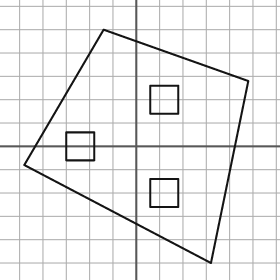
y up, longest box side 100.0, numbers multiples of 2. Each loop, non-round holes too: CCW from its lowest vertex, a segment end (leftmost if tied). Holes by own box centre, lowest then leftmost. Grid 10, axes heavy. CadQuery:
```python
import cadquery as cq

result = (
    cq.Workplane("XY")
    .moveTo(32.0, -50.0)
    .lineTo(48.0, 28.0)
    .lineTo(-14.0, 50.0)
    .lineTo(-48.0, -8.0)
    .close()
    .moveTo(6.0, -26.0)
    .lineTo(18.0, -26.0)
    .lineTo(18.0, -14.0)
    .lineTo(6.0, -14.0)
    .close()
    .moveTo(-30.0, -6.0)
    .lineTo(-18.0, -6.0)
    .lineTo(-18.0, 6.0)
    .lineTo(-30.0, 6.0)
    .close()
    .moveTo(6.0, 14.0)
    .lineTo(18.0, 14.0)
    .lineTo(18.0, 26.0)
    .lineTo(6.0, 26.0)
    .close()
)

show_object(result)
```